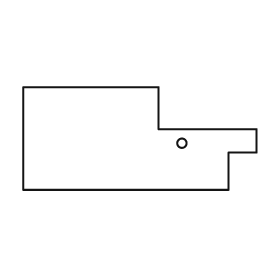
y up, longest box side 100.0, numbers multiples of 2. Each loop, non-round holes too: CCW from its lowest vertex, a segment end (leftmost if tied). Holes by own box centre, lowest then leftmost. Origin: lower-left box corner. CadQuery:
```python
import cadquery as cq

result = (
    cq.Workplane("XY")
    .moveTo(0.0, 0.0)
    .lineTo(88.0, 0.0)
    .lineTo(88.0, 16.0)
    .lineTo(100.0, 16.0)
    .lineTo(100.0, 26.0)
    .lineTo(58.0, 26.0)
    .lineTo(58.0, 44.0)
    .lineTo(0.0, 44.0)
    .close()
    .moveTo(68.0, 20.0)
    .circle(2.0)
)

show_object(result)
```